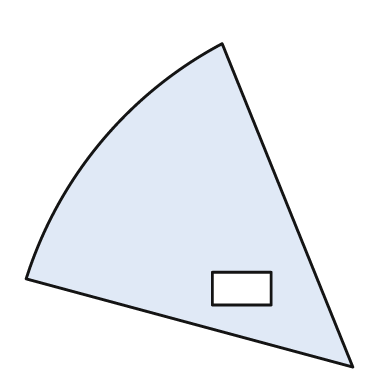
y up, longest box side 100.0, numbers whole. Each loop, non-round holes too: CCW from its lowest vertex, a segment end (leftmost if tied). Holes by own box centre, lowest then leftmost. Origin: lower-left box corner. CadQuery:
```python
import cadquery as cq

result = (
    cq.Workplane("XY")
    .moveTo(100.0, 0.0)
    .lineTo(60.0, 99.0)
    .threePointArc((23.0, 69.0), (0.0, 27.0))
    .close()
    .moveTo(57.0, 19.0)
    .lineTo(75.0, 19.0)
    .lineTo(75.0, 29.0)
    .lineTo(57.0, 29.0)
    .close()
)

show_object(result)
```